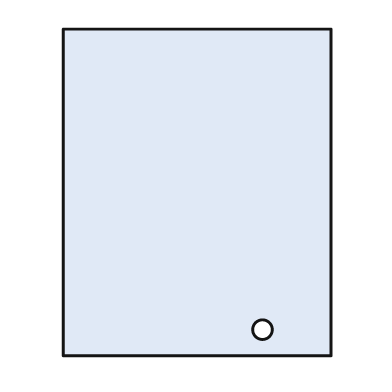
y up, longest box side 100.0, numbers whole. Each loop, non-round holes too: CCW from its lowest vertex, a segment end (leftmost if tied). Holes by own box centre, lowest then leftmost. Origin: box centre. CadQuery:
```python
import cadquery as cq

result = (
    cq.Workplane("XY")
    .moveTo(-41.0, -50.0)
    .lineTo(41.0, -50.0)
    .lineTo(41.0, 50.0)
    .lineTo(-41.0, 50.0)
    .close()
    .moveTo(20.0, -42.0)
    .circle(3.0)
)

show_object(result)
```